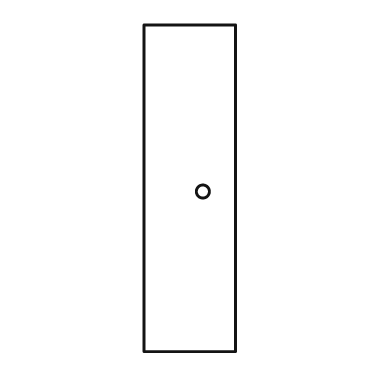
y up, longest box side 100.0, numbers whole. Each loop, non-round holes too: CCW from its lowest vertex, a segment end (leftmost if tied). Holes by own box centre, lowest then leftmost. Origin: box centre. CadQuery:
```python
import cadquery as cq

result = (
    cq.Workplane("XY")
    .moveTo(-14.0, -50.0)
    .lineTo(14.0, -50.0)
    .lineTo(14.0, 50.0)
    .lineTo(-14.0, 50.0)
    .close()
    .moveTo(4.0, -1.0)
    .circle(2.0)
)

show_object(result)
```